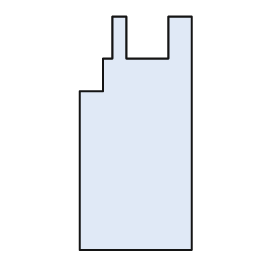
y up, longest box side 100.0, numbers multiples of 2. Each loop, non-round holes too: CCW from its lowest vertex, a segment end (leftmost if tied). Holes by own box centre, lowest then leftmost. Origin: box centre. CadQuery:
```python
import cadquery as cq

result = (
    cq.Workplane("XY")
    .moveTo(-24.0, -50.0)
    .lineTo(24.0, -50.0)
    .lineTo(24.0, 50.0)
    .lineTo(14.0, 50.0)
    .lineTo(14.0, 32.0)
    .lineTo(-4.0, 32.0)
    .lineTo(-4.0, 50.0)
    .lineTo(-10.0, 50.0)
    .lineTo(-10.0, 32.0)
    .lineTo(-14.0, 32.0)
    .lineTo(-14.0, 18.0)
    .lineTo(-24.0, 18.0)
    .close()
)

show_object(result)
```